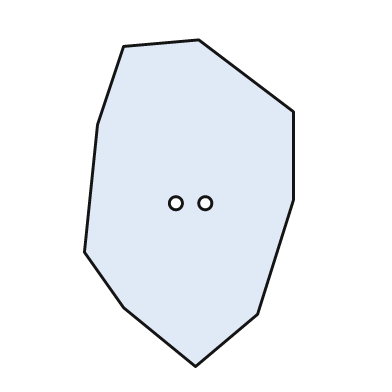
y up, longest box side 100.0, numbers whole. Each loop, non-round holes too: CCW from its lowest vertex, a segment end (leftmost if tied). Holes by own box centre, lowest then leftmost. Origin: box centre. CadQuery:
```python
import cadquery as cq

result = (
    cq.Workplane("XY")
    .moveTo(2.0, -50.0)
    .lineTo(21.0, -34.0)
    .lineTo(32.0, 1.0)
    .lineTo(32.0, 28.0)
    .lineTo(3.0, 50.0)
    .lineTo(-20.0, 48.0)
    .lineTo(-28.0, 24.0)
    .lineTo(-32.0, -15.0)
    .lineTo(-20.0, -32.0)
    .close()
    .moveTo(-4.0, 0.0)
    .circle(2.0)
    .moveTo(5.0, 0.0)
    .circle(2.0)
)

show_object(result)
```